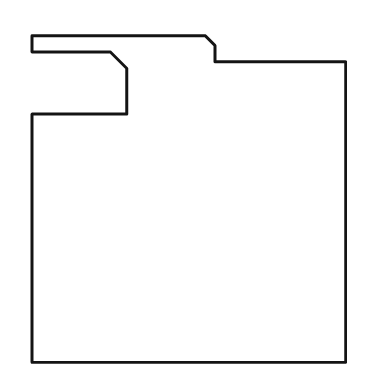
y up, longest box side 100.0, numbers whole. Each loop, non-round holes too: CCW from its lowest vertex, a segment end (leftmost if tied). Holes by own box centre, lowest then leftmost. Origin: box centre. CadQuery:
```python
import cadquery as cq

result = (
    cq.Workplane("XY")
    .moveTo(-48.0, -50.0)
    .lineTo(48.0, -50.0)
    .lineTo(48.0, 42.0)
    .lineTo(8.0, 42.0)
    .lineTo(8.0, 47.0)
    .lineTo(5.0, 50.0)
    .lineTo(-48.0, 50.0)
    .lineTo(-48.0, 45.0)
    .lineTo(-24.0, 45.0)
    .lineTo(-19.0, 40.0)
    .lineTo(-19.0, 26.0)
    .lineTo(-48.0, 26.0)
    .close()
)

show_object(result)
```